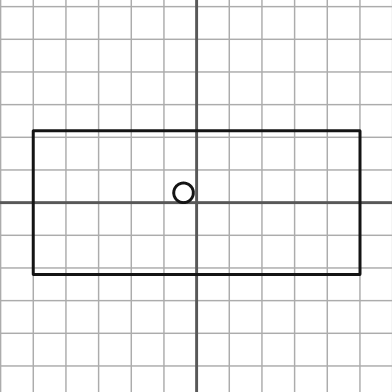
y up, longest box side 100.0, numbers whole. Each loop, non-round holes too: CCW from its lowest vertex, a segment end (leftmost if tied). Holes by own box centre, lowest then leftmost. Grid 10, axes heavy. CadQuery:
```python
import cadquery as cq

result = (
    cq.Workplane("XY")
    .moveTo(-50.0, -22.0)
    .lineTo(50.0, -22.0)
    .lineTo(50.0, 22.0)
    .lineTo(-50.0, 22.0)
    .close()
    .moveTo(-4.0, 3.0)
    .circle(3.0)
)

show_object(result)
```